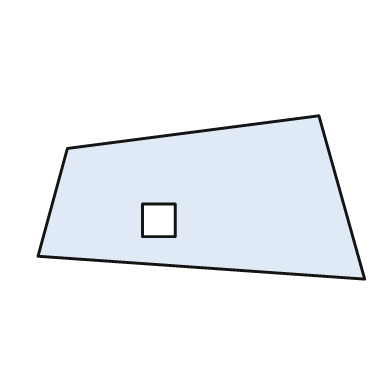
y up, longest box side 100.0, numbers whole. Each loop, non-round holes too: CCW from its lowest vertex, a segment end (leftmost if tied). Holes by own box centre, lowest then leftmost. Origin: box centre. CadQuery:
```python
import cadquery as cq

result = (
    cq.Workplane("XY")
    .moveTo(50.0, -25.0)
    .lineTo(36.0, 25.0)
    .lineTo(-41.0, 15.0)
    .lineTo(-50.0, -18.0)
    .close()
    .moveTo(-18.0, -12.0)
    .lineTo(-8.0, -12.0)
    .lineTo(-8.0, -2.0)
    .lineTo(-18.0, -2.0)
    .close()
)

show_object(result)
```